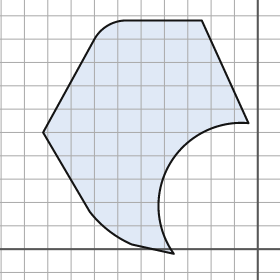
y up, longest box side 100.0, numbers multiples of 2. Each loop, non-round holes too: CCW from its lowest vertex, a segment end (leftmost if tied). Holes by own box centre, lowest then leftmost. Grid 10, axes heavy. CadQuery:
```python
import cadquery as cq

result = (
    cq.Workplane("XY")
    .moveTo(-36.0, -2.0)
    .threePointArc((-38.0, 36.0), (-4.0, 54.0))
    .lineTo(-24.0, 98.0)
    .lineTo(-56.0, 98.0)
    .threePointArc((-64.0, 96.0), (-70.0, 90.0))
    .lineTo(-92.0, 50.0)
    .lineTo(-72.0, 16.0)
    .threePointArc((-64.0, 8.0), (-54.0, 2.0))
    .close()
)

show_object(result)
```